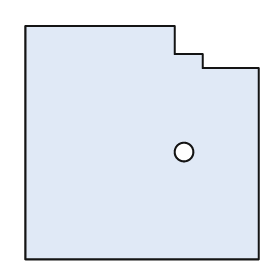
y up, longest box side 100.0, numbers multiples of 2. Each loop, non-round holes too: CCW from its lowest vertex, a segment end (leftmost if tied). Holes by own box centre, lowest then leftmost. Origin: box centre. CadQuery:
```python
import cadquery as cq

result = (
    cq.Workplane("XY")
    .moveTo(-50.0, -50.0)
    .lineTo(50.0, -50.0)
    .lineTo(50.0, 32.0)
    .lineTo(26.0, 32.0)
    .lineTo(26.0, 38.0)
    .lineTo(14.0, 38.0)
    .lineTo(14.0, 50.0)
    .lineTo(-50.0, 50.0)
    .close()
    .moveTo(18.0, -4.0)
    .circle(4.0)
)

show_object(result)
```